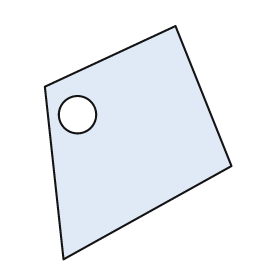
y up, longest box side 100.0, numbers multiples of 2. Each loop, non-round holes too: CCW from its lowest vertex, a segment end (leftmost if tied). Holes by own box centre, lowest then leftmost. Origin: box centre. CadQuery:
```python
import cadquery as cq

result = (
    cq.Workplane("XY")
    .moveTo(-32.0, -50.0)
    .lineTo(40.0, -10.0)
    .lineTo(16.0, 50.0)
    .lineTo(-40.0, 24.0)
    .close()
    .moveTo(-26.0, 12.0)
    .circle(8.0)
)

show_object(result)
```